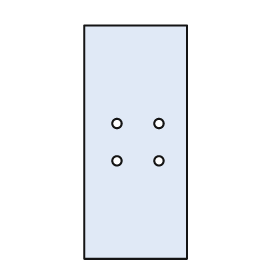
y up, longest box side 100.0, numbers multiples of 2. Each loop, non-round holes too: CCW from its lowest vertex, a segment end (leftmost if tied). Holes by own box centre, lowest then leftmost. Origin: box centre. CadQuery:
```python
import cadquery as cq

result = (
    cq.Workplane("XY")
    .moveTo(-22.0, -50.0)
    .lineTo(22.0, -50.0)
    .lineTo(22.0, 50.0)
    .lineTo(-22.0, 50.0)
    .close()
    .moveTo(-8.0, -8.0)
    .circle(2.0)
    .moveTo(10.0, -8.0)
    .circle(2.0)
    .moveTo(-8.0, 8.0)
    .circle(2.0)
    .moveTo(10.0, 8.0)
    .circle(2.0)
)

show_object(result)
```